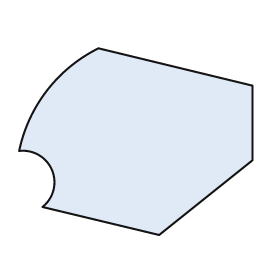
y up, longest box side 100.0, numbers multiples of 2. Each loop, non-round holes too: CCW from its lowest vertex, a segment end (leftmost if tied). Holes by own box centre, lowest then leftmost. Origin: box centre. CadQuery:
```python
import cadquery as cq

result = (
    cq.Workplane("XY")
    .moveTo(10.0, -40.0)
    .lineTo(50.0, -8.0)
    .lineTo(50.0, 24.0)
    .lineTo(-16.0, 40.0)
    .threePointArc((-38.0, 22.0), (-50.0, -4.0))
    .threePointArc((-36.0, -12.0), (-40.0, -28.0))
    .close()
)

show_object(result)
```